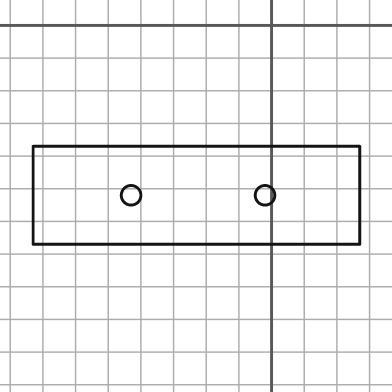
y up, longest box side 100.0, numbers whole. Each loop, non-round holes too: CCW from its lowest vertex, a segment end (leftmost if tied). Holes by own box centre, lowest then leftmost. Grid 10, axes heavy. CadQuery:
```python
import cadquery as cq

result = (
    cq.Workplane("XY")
    .moveTo(-73.0, -67.0)
    .lineTo(27.0, -67.0)
    .lineTo(27.0, -37.0)
    .lineTo(-73.0, -37.0)
    .close()
    .moveTo(-43.0, -52.0)
    .circle(3.0)
    .moveTo(-2.0, -52.0)
    .circle(3.0)
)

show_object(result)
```